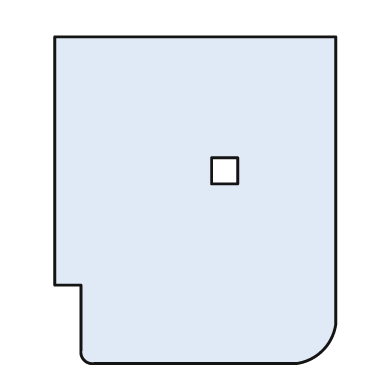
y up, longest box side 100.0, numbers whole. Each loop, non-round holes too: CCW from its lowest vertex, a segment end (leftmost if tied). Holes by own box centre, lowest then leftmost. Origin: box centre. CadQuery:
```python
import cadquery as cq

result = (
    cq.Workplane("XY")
    .moveTo(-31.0, -50.0)
    .lineTo(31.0, -50.0)
    .threePointArc((39.0, -46.0), (43.0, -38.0))
    .lineTo(43.0, 50.0)
    .lineTo(-43.0, 50.0)
    .lineTo(-43.0, -26.0)
    .lineTo(-35.0, -26.0)
    .lineTo(-35.0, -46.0)
    .threePointArc((-34.0, -49.0), (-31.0, -50.0))
    .close()
    .moveTo(5.0, 5.0)
    .lineTo(13.0, 5.0)
    .lineTo(13.0, 13.0)
    .lineTo(5.0, 13.0)
    .close()
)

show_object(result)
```